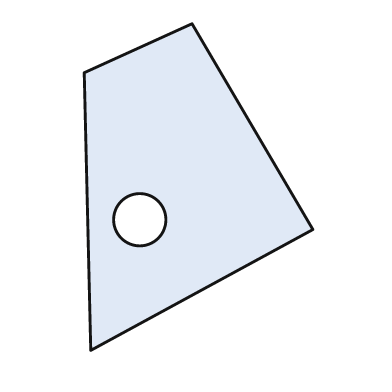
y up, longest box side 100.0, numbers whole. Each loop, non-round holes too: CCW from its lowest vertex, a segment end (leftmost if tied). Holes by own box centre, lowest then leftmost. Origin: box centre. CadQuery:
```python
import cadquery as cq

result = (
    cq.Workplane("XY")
    .moveTo(-33.0, -50.0)
    .lineTo(35.0, -13.0)
    .lineTo(-2.0, 50.0)
    .lineTo(-35.0, 35.0)
    .close()
    .moveTo(-18.0, -10.0)
    .circle(8.0)
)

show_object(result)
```